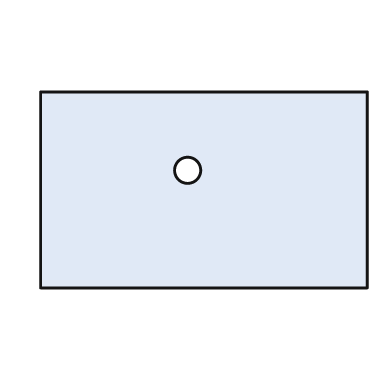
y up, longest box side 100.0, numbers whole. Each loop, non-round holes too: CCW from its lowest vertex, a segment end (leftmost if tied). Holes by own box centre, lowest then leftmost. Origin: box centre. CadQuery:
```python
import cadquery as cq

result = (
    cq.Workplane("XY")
    .moveTo(-50.0, -30.0)
    .lineTo(50.0, -30.0)
    .lineTo(50.0, 30.0)
    .lineTo(-50.0, 30.0)
    .close()
    .moveTo(-5.0, 6.0)
    .circle(4.0)
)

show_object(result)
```